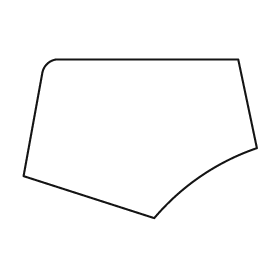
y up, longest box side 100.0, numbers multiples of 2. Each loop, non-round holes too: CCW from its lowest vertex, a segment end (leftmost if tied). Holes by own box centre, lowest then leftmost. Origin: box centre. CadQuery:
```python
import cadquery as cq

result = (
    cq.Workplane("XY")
    .moveTo(6.0, -34.0)
    .threePointArc((26.0, -16.0), (50.0, -4.0))
    .lineTo(42.0, 34.0)
    .lineTo(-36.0, 34.0)
    .threePointArc((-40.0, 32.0), (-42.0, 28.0))
    .lineTo(-50.0, -16.0)
    .close()
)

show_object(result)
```